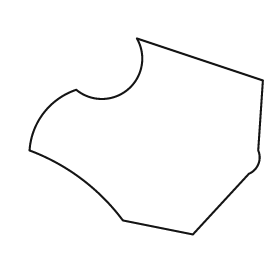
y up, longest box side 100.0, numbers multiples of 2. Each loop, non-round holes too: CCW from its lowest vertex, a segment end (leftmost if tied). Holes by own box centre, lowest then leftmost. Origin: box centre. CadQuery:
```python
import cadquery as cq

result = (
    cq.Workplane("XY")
    .moveTo(20.0, -42.0)
    .lineTo(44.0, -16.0)
    .threePointArc((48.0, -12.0), (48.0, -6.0))
    .lineTo(50.0, 24.0)
    .lineTo(-4.0, 42.0)
    .threePointArc((-8.0, 20.0), (-30.0, 20.0))
    .threePointArc((-44.0, 10.0), (-50.0, -6.0))
    .threePointArc((-28.0, -18.0), (-10.0, -36.0))
    .close()
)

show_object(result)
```